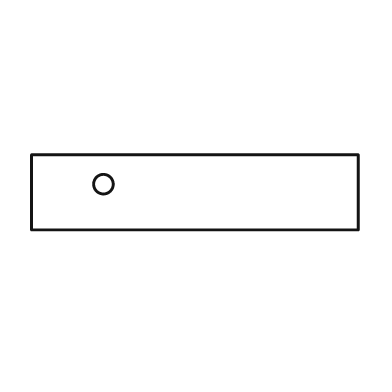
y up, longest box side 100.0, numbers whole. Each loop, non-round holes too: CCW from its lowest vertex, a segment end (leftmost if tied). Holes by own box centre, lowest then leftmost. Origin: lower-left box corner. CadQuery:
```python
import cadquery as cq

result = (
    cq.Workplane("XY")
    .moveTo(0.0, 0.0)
    .lineTo(100.0, 0.0)
    .lineTo(100.0, 23.0)
    .lineTo(0.0, 23.0)
    .close()
    .moveTo(22.0, 14.0)
    .circle(3.0)
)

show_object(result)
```